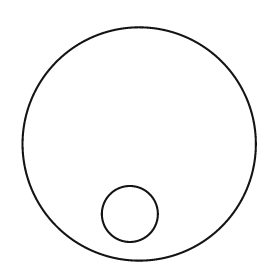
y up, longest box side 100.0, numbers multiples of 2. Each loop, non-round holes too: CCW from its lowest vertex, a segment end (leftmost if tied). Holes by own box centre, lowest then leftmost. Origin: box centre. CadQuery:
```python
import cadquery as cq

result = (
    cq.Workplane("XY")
    .moveTo(0.0, 0.0)
    .circle(50.0)
    .moveTo(-4.0, -30.0)
    .circle(12.0)
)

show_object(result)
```